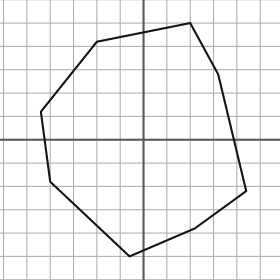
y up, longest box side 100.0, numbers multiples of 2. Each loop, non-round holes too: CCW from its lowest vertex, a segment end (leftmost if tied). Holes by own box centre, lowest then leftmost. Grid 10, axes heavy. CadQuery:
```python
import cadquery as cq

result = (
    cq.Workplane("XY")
    .moveTo(-6.0, -50.0)
    .lineTo(22.0, -38.0)
    .lineTo(44.0, -22.0)
    .lineTo(32.0, 28.0)
    .lineTo(20.0, 50.0)
    .lineTo(-20.0, 42.0)
    .lineTo(-44.0, 12.0)
    .lineTo(-40.0, -18.0)
    .close()
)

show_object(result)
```